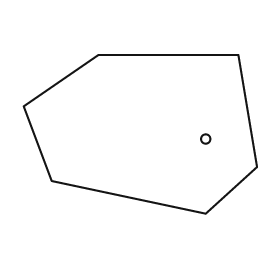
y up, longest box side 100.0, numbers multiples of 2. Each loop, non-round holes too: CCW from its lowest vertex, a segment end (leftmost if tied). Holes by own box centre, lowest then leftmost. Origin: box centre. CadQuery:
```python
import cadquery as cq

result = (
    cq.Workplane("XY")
    .moveTo(28.0, -34.0)
    .lineTo(50.0, -14.0)
    .lineTo(42.0, 34.0)
    .lineTo(-18.0, 34.0)
    .lineTo(-50.0, 12.0)
    .lineTo(-38.0, -20.0)
    .close()
    .moveTo(28.0, -2.0)
    .circle(2.0)
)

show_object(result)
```